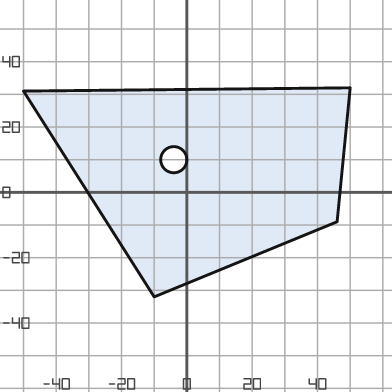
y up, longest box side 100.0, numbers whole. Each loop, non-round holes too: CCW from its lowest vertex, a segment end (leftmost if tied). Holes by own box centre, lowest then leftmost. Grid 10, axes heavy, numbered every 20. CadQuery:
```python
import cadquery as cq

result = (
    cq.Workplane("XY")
    .moveTo(-10.0, -32.0)
    .lineTo(46.0, -9.0)
    .lineTo(50.0, 32.0)
    .lineTo(-50.0, 31.0)
    .close()
    .moveTo(-4.0, 10.0)
    .circle(4.0)
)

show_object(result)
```